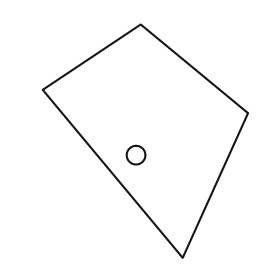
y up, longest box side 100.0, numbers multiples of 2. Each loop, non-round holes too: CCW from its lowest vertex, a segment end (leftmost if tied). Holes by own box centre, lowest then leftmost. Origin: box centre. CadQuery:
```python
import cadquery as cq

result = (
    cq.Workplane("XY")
    .moveTo(16.0, -50.0)
    .lineTo(44.0, 12.0)
    .lineTo(-2.0, 50.0)
    .lineTo(-44.0, 22.0)
    .close()
    .moveTo(-4.0, -6.0)
    .circle(4.0)
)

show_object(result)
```